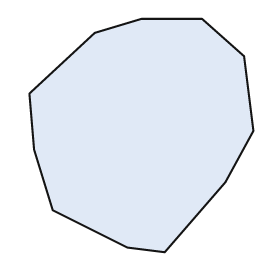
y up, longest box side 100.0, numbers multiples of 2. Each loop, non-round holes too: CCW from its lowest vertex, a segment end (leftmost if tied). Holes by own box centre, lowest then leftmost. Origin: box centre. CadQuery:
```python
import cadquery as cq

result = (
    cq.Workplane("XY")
    .moveTo(10.0, -50.0)
    .lineTo(36.0, -20.0)
    .lineTo(48.0, 2.0)
    .lineTo(44.0, 34.0)
    .lineTo(26.0, 50.0)
    .lineTo(0.0, 50.0)
    .lineTo(-20.0, 44.0)
    .lineTo(-48.0, 18.0)
    .lineTo(-46.0, -6.0)
    .lineTo(-38.0, -32.0)
    .lineTo(-6.0, -48.0)
    .close()
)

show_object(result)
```